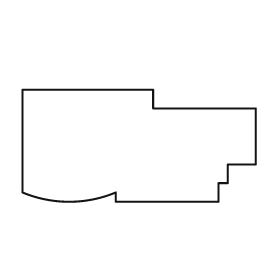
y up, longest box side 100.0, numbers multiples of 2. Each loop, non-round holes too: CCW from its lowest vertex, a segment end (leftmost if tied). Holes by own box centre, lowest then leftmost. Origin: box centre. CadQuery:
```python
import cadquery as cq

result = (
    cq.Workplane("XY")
    .moveTo(-10.0, -24.0)
    .lineTo(34.0, -24.0)
    .lineTo(34.0, -16.0)
    .lineTo(38.0, -16.0)
    .lineTo(38.0, -8.0)
    .lineTo(50.0, -8.0)
    .lineTo(50.0, 16.0)
    .lineTo(6.0, 16.0)
    .lineTo(6.0, 24.0)
    .lineTo(-50.0, 24.0)
    .lineTo(-50.0, -20.0)
    .threePointArc((-30.0, -24.0), (-10.0, -20.0))
    .close()
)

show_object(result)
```